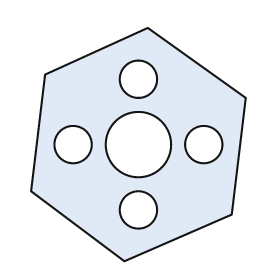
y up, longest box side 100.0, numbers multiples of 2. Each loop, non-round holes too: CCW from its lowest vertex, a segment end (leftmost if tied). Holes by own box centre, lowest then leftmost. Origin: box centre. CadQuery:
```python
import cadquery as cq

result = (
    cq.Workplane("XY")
    .moveTo(-6.0, -50.0)
    .lineTo(40.0, -30.0)
    .lineTo(46.0, 20.0)
    .lineTo(4.0, 50.0)
    .lineTo(-40.0, 30.0)
    .lineTo(-46.0, -20.0)
    .close()
    .moveTo(0.0, -28.0)
    .circle(8.0)
    .moveTo(-28.0, 0.0)
    .circle(8.0)
    .moveTo(0.0, 0.0)
    .circle(14.0)
    .moveTo(28.0, 0.0)
    .circle(8.0)
    .moveTo(0.0, 28.0)
    .circle(8.0)
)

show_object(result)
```